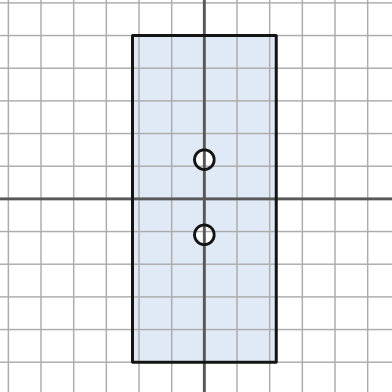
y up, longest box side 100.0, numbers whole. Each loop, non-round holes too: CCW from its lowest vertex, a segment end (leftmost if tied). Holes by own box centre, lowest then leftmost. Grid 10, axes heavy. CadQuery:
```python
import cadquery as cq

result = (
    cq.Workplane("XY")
    .moveTo(-22.0, -50.0)
    .lineTo(22.0, -50.0)
    .lineTo(22.0, 50.0)
    .lineTo(-22.0, 50.0)
    .close()
    .moveTo(0.0, -11.0)
    .circle(3.0)
    .moveTo(0.0, 12.0)
    .circle(3.0)
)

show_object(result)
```